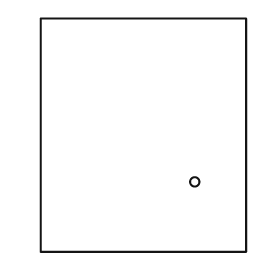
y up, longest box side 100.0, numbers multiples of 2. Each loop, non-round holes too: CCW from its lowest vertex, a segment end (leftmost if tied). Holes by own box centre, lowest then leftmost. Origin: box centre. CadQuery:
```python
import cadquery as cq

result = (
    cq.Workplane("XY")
    .moveTo(-44.0, -50.0)
    .lineTo(44.0, -50.0)
    .lineTo(44.0, 50.0)
    .lineTo(-44.0, 50.0)
    .close()
    .moveTo(22.0, -20.0)
    .circle(2.0)
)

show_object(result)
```